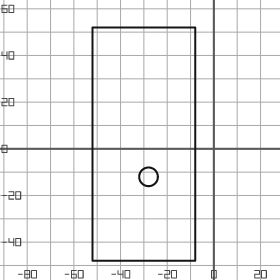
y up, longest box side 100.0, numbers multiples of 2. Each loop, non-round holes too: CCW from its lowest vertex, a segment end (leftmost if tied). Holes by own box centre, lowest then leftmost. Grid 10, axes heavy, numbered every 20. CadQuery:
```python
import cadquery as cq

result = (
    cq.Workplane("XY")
    .moveTo(-52.0, -48.0)
    .lineTo(-8.0, -48.0)
    .lineTo(-8.0, 52.0)
    .lineTo(-52.0, 52.0)
    .close()
    .moveTo(-28.0, -12.0)
    .circle(4.0)
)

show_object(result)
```